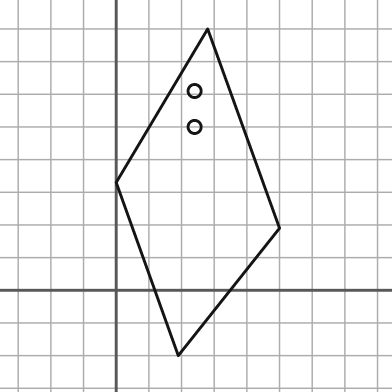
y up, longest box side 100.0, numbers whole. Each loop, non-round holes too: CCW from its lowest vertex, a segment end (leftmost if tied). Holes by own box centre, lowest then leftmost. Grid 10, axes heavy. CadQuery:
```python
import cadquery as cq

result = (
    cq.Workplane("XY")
    .moveTo(19.0, -20.0)
    .lineTo(50.0, 19.0)
    .lineTo(28.0, 80.0)
    .lineTo(0.0, 33.0)
    .close()
    .moveTo(24.0, 50.0)
    .circle(2.0)
    .moveTo(24.0, 61.0)
    .circle(2.0)
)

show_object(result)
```